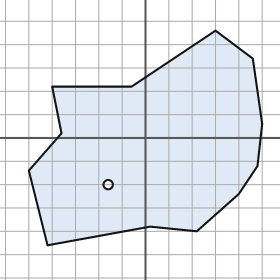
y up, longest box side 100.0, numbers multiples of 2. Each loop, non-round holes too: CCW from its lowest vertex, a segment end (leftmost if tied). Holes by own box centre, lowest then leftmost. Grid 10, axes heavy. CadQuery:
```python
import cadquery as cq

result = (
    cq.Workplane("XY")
    .moveTo(-42.0, -46.0)
    .lineTo(2.0, -38.0)
    .lineTo(22.0, -40.0)
    .lineTo(40.0, -24.0)
    .lineTo(48.0, -12.0)
    .lineTo(50.0, 6.0)
    .lineTo(46.0, 34.0)
    .lineTo(30.0, 46.0)
    .lineTo(-6.0, 22.0)
    .lineTo(-40.0, 22.0)
    .lineTo(-36.0, 2.0)
    .lineTo(-50.0, -14.0)
    .close()
    .moveTo(-16.0, -20.0)
    .circle(2.0)
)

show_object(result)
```